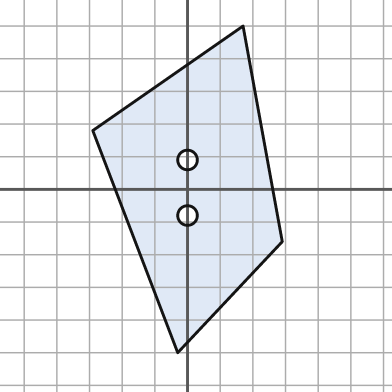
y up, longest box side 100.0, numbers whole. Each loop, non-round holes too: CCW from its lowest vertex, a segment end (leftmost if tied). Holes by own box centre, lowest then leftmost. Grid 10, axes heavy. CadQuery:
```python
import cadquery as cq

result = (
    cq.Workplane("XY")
    .moveTo(-3.0, -50.0)
    .lineTo(29.0, -16.0)
    .lineTo(17.0, 50.0)
    .lineTo(-29.0, 18.0)
    .close()
    .moveTo(0.0, -8.0)
    .circle(3.0)
    .moveTo(0.0, 9.0)
    .circle(3.0)
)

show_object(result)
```